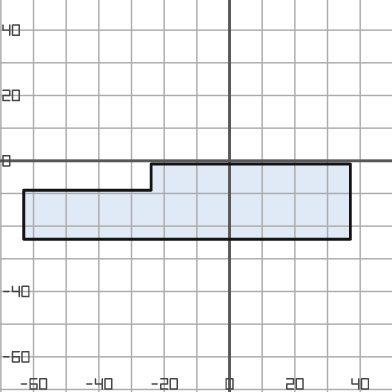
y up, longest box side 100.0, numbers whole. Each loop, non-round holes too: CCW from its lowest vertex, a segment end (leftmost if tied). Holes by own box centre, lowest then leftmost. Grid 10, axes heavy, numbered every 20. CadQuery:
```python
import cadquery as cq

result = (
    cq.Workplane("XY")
    .moveTo(-63.0, -24.0)
    .lineTo(37.0, -24.0)
    .lineTo(37.0, -1.0)
    .lineTo(-24.0, -1.0)
    .lineTo(-24.0, -9.0)
    .lineTo(-63.0, -9.0)
    .close()
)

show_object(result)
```